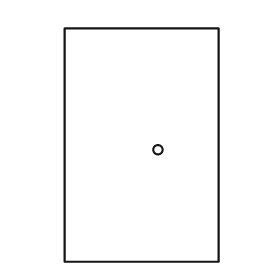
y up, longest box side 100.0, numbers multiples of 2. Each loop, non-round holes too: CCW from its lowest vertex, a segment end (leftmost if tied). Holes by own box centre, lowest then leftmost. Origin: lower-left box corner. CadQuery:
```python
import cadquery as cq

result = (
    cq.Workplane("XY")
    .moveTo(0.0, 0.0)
    .lineTo(66.0, 0.0)
    .lineTo(66.0, 100.0)
    .lineTo(0.0, 100.0)
    .close()
    .moveTo(40.0, 48.0)
    .circle(2.0)
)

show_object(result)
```